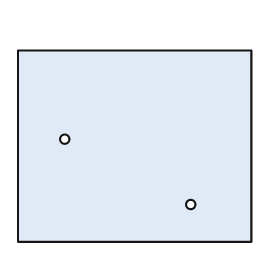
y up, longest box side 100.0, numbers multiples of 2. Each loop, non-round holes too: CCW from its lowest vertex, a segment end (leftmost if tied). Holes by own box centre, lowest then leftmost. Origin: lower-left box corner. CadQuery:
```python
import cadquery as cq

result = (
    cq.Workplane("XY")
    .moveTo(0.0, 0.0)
    .lineTo(100.0, 0.0)
    .lineTo(100.0, 82.0)
    .lineTo(0.0, 82.0)
    .close()
    .moveTo(74.0, 16.0)
    .circle(2.0)
    .moveTo(20.0, 44.0)
    .circle(2.0)
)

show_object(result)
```